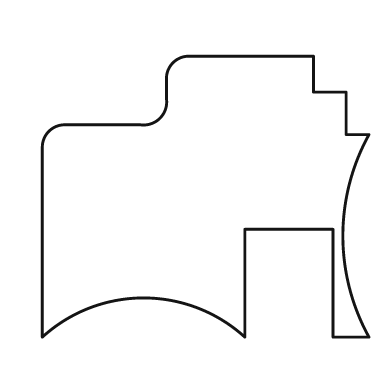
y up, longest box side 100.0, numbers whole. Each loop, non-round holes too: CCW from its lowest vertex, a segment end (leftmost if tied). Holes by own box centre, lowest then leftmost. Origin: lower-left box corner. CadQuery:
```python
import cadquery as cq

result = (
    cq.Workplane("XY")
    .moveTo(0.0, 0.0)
    .threePointArc((31.0, 12.0), (62.0, 0.0))
    .lineTo(62.0, 33.0)
    .lineTo(89.0, 33.0)
    .lineTo(89.0, 0.0)
    .lineTo(100.0, 0.0)
    .threePointArc((92.0, 31.0), (100.0, 62.0))
    .lineTo(93.0, 62.0)
    .lineTo(93.0, 75.0)
    .lineTo(83.0, 75.0)
    .lineTo(83.0, 86.0)
    .lineTo(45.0, 86.0)
    .threePointArc((40.0, 84.0), (38.0, 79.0))
    .lineTo(38.0, 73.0)
    .threePointArc((36.0, 67.0), (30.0, 65.0))
    .lineTo(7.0, 65.0)
    .threePointArc((2.0, 63.0), (0.0, 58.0))
    .close()
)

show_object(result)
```